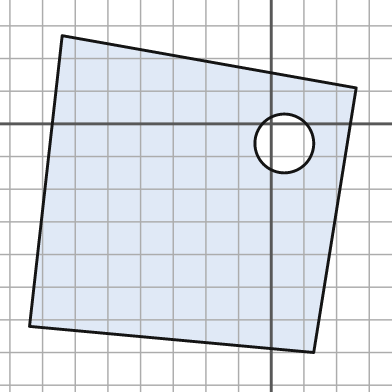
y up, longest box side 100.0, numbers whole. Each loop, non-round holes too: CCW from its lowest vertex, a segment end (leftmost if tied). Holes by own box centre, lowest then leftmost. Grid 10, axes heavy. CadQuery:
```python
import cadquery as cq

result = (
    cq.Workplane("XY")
    .moveTo(13.0, -70.0)
    .lineTo(26.0, 11.0)
    .lineTo(-64.0, 27.0)
    .lineTo(-74.0, -62.0)
    .close()
    .moveTo(4.0, -6.0)
    .circle(9.0)
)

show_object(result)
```